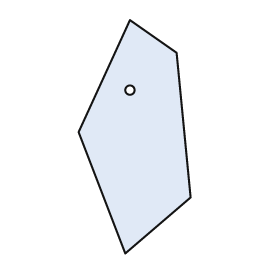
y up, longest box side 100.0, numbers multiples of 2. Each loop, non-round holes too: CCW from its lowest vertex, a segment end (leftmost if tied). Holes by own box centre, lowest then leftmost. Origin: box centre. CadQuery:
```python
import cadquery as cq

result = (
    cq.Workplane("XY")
    .moveTo(-4.0, -50.0)
    .lineTo(24.0, -26.0)
    .lineTo(18.0, 36.0)
    .lineTo(-2.0, 50.0)
    .lineTo(-24.0, 2.0)
    .close()
    .moveTo(-2.0, 20.0)
    .circle(2.0)
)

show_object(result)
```